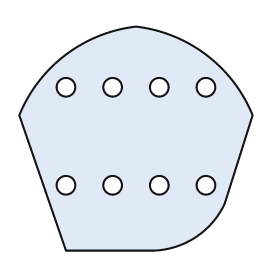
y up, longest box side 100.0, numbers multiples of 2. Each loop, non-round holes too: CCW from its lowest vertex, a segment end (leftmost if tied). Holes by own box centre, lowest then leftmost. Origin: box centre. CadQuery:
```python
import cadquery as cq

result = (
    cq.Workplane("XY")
    .moveTo(-30.0, -48.0)
    .lineTo(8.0, -48.0)
    .threePointArc((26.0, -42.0), (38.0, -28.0))
    .lineTo(50.0, 10.0)
    .threePointArc((30.0, 36.0), (0.0, 48.0))
    .threePointArc((-30.0, 36.0), (-50.0, 10.0))
    .close()
    .moveTo(-30.0, -20.0)
    .circle(4.0)
    .moveTo(-10.0, -20.0)
    .circle(4.0)
    .moveTo(10.0, -20.0)
    .circle(4.0)
    .moveTo(30.0, -20.0)
    .circle(4.0)
    .moveTo(-30.0, 22.0)
    .circle(4.0)
    .moveTo(-10.0, 22.0)
    .circle(4.0)
    .moveTo(10.0, 22.0)
    .circle(4.0)
    .moveTo(30.0, 22.0)
    .circle(4.0)
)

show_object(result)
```